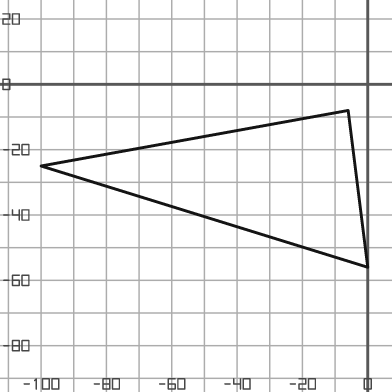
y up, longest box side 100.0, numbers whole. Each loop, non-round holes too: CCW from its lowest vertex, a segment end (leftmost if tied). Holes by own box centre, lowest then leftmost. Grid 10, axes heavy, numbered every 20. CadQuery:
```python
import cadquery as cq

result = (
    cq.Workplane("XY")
    .moveTo(0.0, -56.0)
    .lineTo(-6.0, -8.0)
    .lineTo(-100.0, -25.0)
    .close()
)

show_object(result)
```